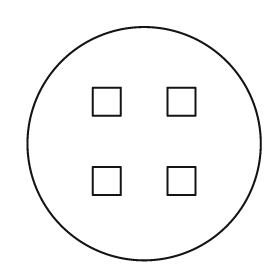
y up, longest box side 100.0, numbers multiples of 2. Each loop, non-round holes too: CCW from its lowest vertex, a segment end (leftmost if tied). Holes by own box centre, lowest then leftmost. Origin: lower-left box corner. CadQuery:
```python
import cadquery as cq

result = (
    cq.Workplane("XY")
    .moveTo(50.0, 50.0)
    .circle(50.0)
    .moveTo(28.0, 28.0)
    .lineTo(40.0, 28.0)
    .lineTo(40.0, 40.0)
    .lineTo(28.0, 40.0)
    .close()
    .moveTo(60.0, 28.0)
    .lineTo(72.0, 28.0)
    .lineTo(72.0, 40.0)
    .lineTo(60.0, 40.0)
    .close()
    .moveTo(28.0, 62.0)
    .lineTo(40.0, 62.0)
    .lineTo(40.0, 74.0)
    .lineTo(28.0, 74.0)
    .close()
    .moveTo(60.0, 62.0)
    .lineTo(72.0, 62.0)
    .lineTo(72.0, 74.0)
    .lineTo(60.0, 74.0)
    .close()
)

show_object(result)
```